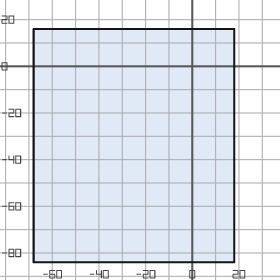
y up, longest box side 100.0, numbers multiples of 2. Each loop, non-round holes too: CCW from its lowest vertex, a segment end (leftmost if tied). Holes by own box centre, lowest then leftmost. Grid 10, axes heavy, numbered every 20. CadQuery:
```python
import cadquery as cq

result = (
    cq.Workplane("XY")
    .moveTo(-68.0, -84.0)
    .lineTo(18.0, -84.0)
    .lineTo(18.0, 16.0)
    .lineTo(-68.0, 16.0)
    .close()
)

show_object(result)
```